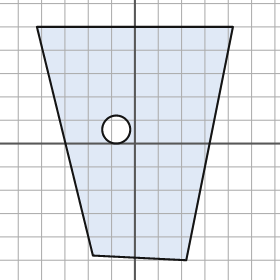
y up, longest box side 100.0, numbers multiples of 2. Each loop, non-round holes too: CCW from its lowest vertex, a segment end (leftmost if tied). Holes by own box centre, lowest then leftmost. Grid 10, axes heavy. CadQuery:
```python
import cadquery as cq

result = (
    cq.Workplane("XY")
    .moveTo(22.0, -50.0)
    .lineTo(42.0, 50.0)
    .lineTo(-42.0, 50.0)
    .lineTo(-18.0, -48.0)
    .close()
    .moveTo(-8.0, 6.0)
    .circle(6.0)
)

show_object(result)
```